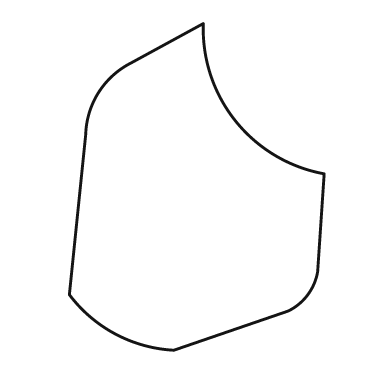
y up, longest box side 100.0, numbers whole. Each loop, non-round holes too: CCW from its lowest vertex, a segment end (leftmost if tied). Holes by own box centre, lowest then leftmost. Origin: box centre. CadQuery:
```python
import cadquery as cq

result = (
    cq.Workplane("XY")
    .moveTo(-7.0, -50.0)
    .lineTo(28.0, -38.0)
    .threePointArc((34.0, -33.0), (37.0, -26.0))
    .lineTo(39.0, 4.0)
    .threePointArc((12.0, 20.0), (2.0, 50.0))
    .lineTo(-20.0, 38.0)
    .threePointArc((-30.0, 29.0), (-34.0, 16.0))
    .lineTo(-39.0, -33.0)
    .threePointArc((-25.0, -45.0), (-7.0, -50.0))
    .close()
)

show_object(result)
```